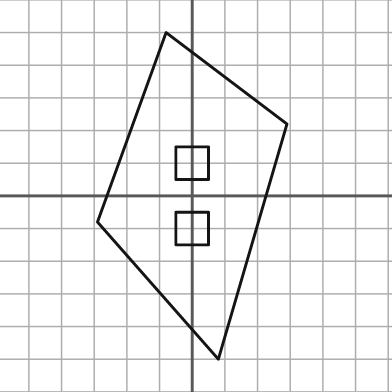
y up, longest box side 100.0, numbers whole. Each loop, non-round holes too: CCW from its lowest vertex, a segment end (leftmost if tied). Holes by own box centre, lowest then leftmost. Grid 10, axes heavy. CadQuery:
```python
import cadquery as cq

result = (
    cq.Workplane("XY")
    .moveTo(8.0, -50.0)
    .lineTo(29.0, 22.0)
    .lineTo(-8.0, 50.0)
    .lineTo(-29.0, -8.0)
    .close()
    .moveTo(-5.0, -15.0)
    .lineTo(5.0, -15.0)
    .lineTo(5.0, -5.0)
    .lineTo(-5.0, -5.0)
    .close()
    .moveTo(-5.0, 5.0)
    .lineTo(5.0, 5.0)
    .lineTo(5.0, 15.0)
    .lineTo(-5.0, 15.0)
    .close()
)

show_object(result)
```